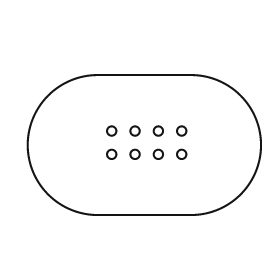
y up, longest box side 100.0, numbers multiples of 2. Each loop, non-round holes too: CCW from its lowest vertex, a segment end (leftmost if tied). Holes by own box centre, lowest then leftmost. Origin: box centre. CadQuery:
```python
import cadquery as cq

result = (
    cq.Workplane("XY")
    .moveTo(-20.0, -30.0)
    .lineTo(20.0, -30.0)
    .threePointArc((50.0, 0.0), (20.0, 30.0))
    .lineTo(-20.0, 30.0)
    .threePointArc((-50.0, 0.0), (-20.0, -30.0))
    .close()
    .moveTo(-14.0, -4.0)
    .circle(2.0)
    .moveTo(-4.0, -4.0)
    .circle(2.0)
    .moveTo(6.0, -4.0)
    .circle(2.0)
    .moveTo(16.0, -4.0)
    .circle(2.0)
    .moveTo(-14.0, 6.0)
    .circle(2.0)
    .moveTo(-4.0, 6.0)
    .circle(2.0)
    .moveTo(6.0, 6.0)
    .circle(2.0)
    .moveTo(16.0, 6.0)
    .circle(2.0)
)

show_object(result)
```